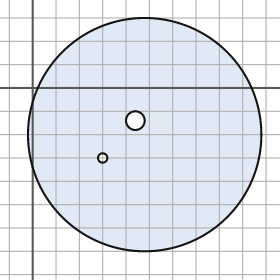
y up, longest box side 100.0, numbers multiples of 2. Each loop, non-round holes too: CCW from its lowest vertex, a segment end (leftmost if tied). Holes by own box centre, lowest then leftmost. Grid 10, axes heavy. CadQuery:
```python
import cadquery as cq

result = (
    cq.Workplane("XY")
    .moveTo(48.0, -20.0)
    .circle(50.0)
    .moveTo(30.0, -30.0)
    .circle(2.0)
    .moveTo(44.0, -14.0)
    .circle(4.0)
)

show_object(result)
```